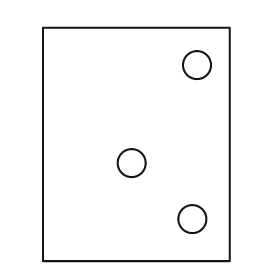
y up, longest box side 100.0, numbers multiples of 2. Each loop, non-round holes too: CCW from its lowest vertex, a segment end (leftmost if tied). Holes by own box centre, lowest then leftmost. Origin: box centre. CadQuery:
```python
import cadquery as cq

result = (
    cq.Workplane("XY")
    .moveTo(-40.0, -50.0)
    .lineTo(40.0, -50.0)
    .lineTo(40.0, 50.0)
    .lineTo(-40.0, 50.0)
    .close()
    .moveTo(24.0, -32.0)
    .circle(6.0)
    .moveTo(-2.0, -8.0)
    .circle(6.0)
    .moveTo(26.0, 34.0)
    .circle(6.0)
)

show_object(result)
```